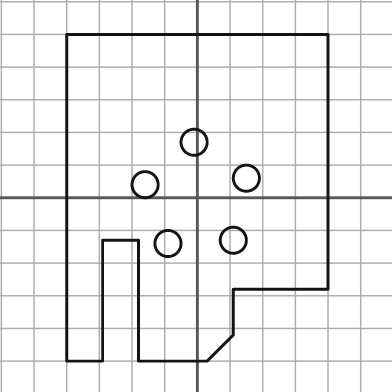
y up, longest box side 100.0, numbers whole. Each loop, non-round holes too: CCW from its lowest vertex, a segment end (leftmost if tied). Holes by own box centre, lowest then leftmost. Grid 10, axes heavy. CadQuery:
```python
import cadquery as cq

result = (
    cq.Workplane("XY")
    .moveTo(-40.0, -50.0)
    .lineTo(-29.0, -50.0)
    .lineTo(-29.0, -13.0)
    .lineTo(-18.0, -13.0)
    .lineTo(-18.0, -50.0)
    .lineTo(3.0, -50.0)
    .lineTo(11.0, -42.0)
    .lineTo(11.0, -28.0)
    .lineTo(40.0, -28.0)
    .lineTo(40.0, 50.0)
    .lineTo(-40.0, 50.0)
    .close()
    .moveTo(-9.0, -14.0)
    .circle(4.0)
    .moveTo(11.0, -13.0)
    .circle(4.0)
    .moveTo(-16.0, 4.0)
    .circle(4.0)
    .moveTo(15.0, 6.0)
    .circle(4.0)
    .moveTo(-1.0, 17.0)
    .circle(4.0)
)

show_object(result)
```